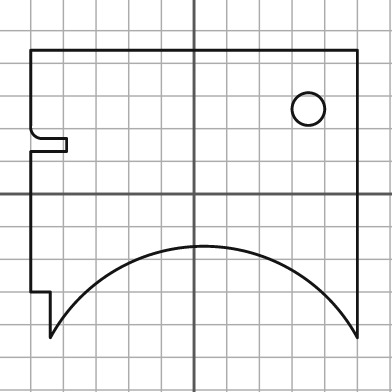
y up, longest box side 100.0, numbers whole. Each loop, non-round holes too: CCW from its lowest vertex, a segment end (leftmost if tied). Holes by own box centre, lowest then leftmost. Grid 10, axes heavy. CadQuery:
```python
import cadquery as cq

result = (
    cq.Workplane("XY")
    .moveTo(-44.0, -44.0)
    .threePointArc((3.0, -16.0), (50.0, -44.0))
    .lineTo(50.0, 44.0)
    .lineTo(-50.0, 44.0)
    .lineTo(-50.0, 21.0)
    .threePointArc((-49.0, 18.0), (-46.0, 17.0))
    .lineTo(-39.0, 17.0)
    .lineTo(-39.0, 13.0)
    .lineTo(-50.0, 13.0)
    .lineTo(-50.0, -30.0)
    .lineTo(-44.0, -30.0)
    .close()
    .moveTo(35.0, 26.0)
    .circle(5.0)
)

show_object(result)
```